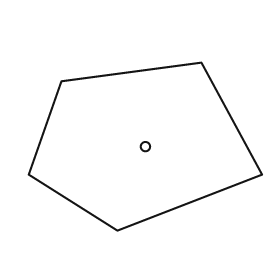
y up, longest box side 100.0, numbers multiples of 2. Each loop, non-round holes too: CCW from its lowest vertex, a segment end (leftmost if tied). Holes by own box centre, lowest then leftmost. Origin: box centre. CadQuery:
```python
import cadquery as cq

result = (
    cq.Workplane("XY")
    .moveTo(-12.0, -36.0)
    .lineTo(50.0, -12.0)
    .lineTo(24.0, 36.0)
    .lineTo(-36.0, 28.0)
    .lineTo(-50.0, -12.0)
    .close()
    .moveTo(0.0, 0.0)
    .circle(2.0)
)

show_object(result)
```